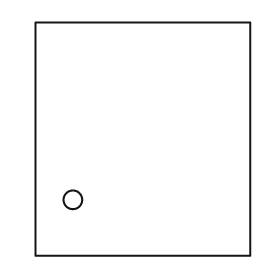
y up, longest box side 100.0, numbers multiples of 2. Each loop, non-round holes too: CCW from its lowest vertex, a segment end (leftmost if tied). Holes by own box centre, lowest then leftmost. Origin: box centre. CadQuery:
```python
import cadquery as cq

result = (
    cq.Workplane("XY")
    .moveTo(-46.0, -50.0)
    .lineTo(46.0, -50.0)
    .lineTo(46.0, 50.0)
    .lineTo(-46.0, 50.0)
    .close()
    .moveTo(-30.0, -26.0)
    .circle(4.0)
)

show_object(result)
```